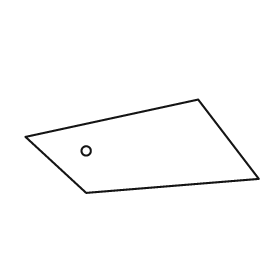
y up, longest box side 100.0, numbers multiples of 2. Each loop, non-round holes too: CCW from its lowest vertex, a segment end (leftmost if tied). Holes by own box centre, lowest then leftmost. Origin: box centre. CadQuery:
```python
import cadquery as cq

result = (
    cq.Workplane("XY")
    .moveTo(-24.0, -20.0)
    .lineTo(50.0, -14.0)
    .lineTo(24.0, 20.0)
    .lineTo(-50.0, 4.0)
    .close()
    .moveTo(-24.0, -2.0)
    .circle(2.0)
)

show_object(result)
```